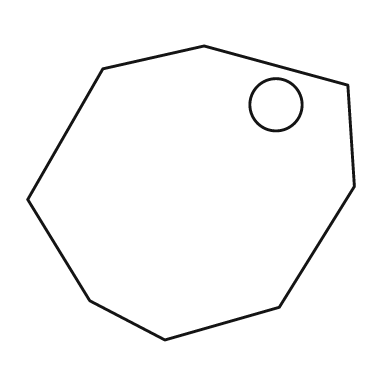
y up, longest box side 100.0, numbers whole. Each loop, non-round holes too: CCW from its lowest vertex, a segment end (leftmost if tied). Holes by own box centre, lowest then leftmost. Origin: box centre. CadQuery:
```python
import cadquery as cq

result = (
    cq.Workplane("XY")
    .moveTo(-8.0, -45.0)
    .lineTo(27.0, -35.0)
    .lineTo(50.0, 2.0)
    .lineTo(48.0, 33.0)
    .lineTo(4.0, 45.0)
    .lineTo(-27.0, 38.0)
    .lineTo(-50.0, -2.0)
    .lineTo(-31.0, -33.0)
    .close()
    .moveTo(26.0, 27.0)
    .circle(8.0)
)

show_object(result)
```